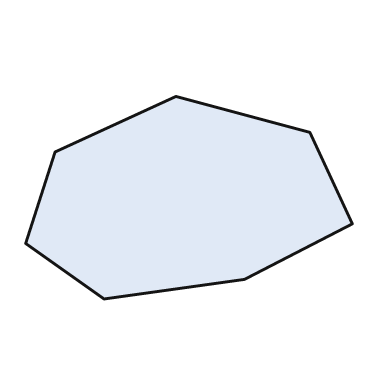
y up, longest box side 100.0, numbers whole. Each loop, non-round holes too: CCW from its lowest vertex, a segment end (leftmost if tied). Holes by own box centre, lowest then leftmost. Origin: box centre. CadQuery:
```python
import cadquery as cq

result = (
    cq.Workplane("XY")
    .moveTo(-26.0, -31.0)
    .lineTo(17.0, -25.0)
    .lineTo(50.0, -8.0)
    .lineTo(37.0, 20.0)
    .lineTo(-4.0, 31.0)
    .lineTo(-41.0, 14.0)
    .lineTo(-50.0, -14.0)
    .close()
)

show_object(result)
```